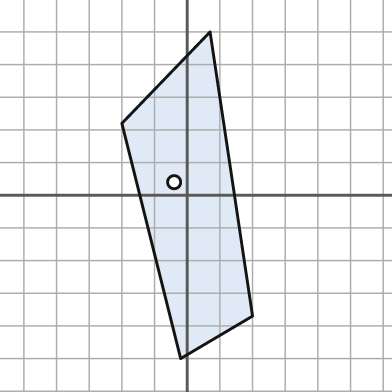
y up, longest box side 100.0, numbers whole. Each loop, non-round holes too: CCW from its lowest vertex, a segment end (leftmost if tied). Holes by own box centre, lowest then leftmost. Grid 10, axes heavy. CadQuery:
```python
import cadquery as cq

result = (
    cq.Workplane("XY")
    .moveTo(-2.0, -50.0)
    .lineTo(20.0, -37.0)
    .lineTo(7.0, 50.0)
    .lineTo(-20.0, 22.0)
    .close()
    .moveTo(-4.0, 4.0)
    .circle(2.0)
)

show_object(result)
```